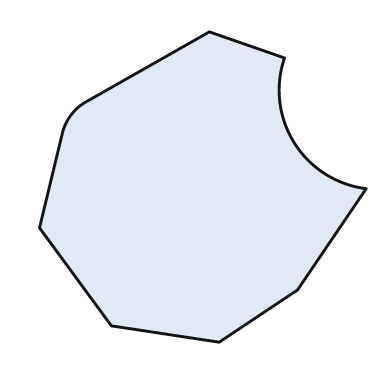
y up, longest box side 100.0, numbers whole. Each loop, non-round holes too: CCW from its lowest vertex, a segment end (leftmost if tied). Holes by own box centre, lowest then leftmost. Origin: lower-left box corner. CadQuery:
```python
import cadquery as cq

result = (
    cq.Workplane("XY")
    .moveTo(55.0, 0.0)
    .lineTo(79.0, 16.0)
    .lineTo(100.0, 47.0)
    .threePointArc((78.0, 61.0), (75.0, 87.0))
    .lineTo(52.0, 95.0)
    .lineTo(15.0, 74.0)
    .threePointArc((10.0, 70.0), (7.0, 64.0))
    .lineTo(0.0, 35.0)
    .lineTo(22.0, 5.0)
    .close()
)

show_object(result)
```